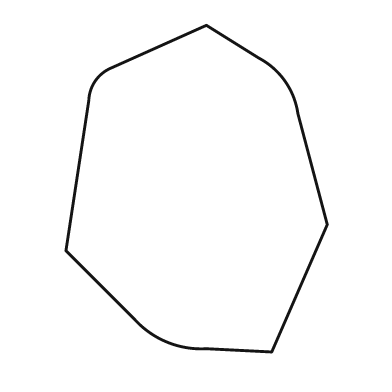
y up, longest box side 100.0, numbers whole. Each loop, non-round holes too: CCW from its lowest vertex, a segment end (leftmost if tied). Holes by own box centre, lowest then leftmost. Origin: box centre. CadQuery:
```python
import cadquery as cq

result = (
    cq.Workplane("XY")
    .moveTo(23.0, -50.0)
    .lineTo(40.0, -11.0)
    .lineTo(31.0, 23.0)
    .threePointArc((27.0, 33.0), (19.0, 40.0))
    .lineTo(3.0, 50.0)
    .lineTo(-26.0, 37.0)
    .threePointArc((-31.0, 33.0), (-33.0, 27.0))
    .lineTo(-40.0, -19.0)
    .lineTo(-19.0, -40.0)
    .threePointArc((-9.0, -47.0), (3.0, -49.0))
    .close()
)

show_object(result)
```